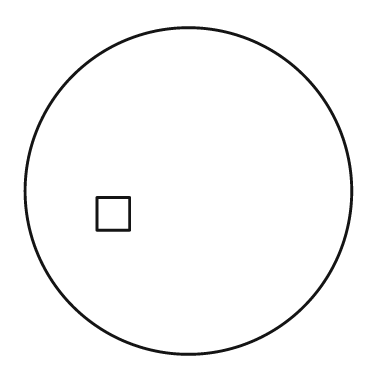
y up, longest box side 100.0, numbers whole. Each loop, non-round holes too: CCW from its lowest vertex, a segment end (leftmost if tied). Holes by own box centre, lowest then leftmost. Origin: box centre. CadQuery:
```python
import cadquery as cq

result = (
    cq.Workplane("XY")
    .moveTo(0.0, 0.0)
    .circle(50.0)
    .moveTo(-28.0, -12.0)
    .lineTo(-18.0, -12.0)
    .lineTo(-18.0, -2.0)
    .lineTo(-28.0, -2.0)
    .close()
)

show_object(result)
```